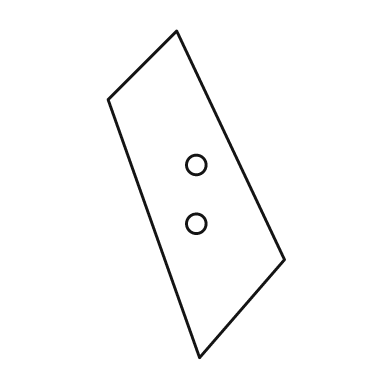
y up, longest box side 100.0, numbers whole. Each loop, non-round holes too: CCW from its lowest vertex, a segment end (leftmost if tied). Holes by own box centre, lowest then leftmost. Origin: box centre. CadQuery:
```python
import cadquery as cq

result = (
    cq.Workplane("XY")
    .moveTo(1.0, -50.0)
    .lineTo(27.0, -20.0)
    .lineTo(-6.0, 50.0)
    .lineTo(-27.0, 29.0)
    .close()
    .moveTo(0.0, -9.0)
    .circle(3.0)
    .moveTo(0.0, 9.0)
    .circle(3.0)
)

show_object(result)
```